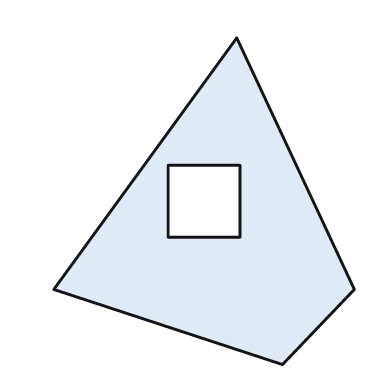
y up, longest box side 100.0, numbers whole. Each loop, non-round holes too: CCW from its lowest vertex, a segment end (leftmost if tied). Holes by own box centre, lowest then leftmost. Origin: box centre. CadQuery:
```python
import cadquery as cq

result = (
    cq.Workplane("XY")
    .moveTo(24.0, -50.0)
    .lineTo(46.0, -27.0)
    .lineTo(10.0, 50.0)
    .lineTo(-46.0, -27.0)
    .close()
    .moveTo(-11.0, -11.0)
    .lineTo(11.0, -11.0)
    .lineTo(11.0, 11.0)
    .lineTo(-11.0, 11.0)
    .close()
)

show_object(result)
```